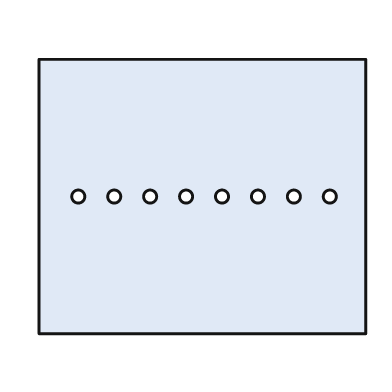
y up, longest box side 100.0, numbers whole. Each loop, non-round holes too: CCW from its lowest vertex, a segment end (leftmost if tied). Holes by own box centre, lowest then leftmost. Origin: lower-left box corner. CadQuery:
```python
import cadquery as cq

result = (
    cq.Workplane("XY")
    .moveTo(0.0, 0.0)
    .lineTo(100.0, 0.0)
    .lineTo(100.0, 84.0)
    .lineTo(0.0, 84.0)
    .close()
    .moveTo(12.0, 42.0)
    .circle(2.0)
    .moveTo(23.0, 42.0)
    .circle(2.0)
    .moveTo(34.0, 42.0)
    .circle(2.0)
    .moveTo(45.0, 42.0)
    .circle(2.0)
    .moveTo(56.0, 42.0)
    .circle(2.0)
    .moveTo(67.0, 42.0)
    .circle(2.0)
    .moveTo(78.0, 42.0)
    .circle(2.0)
    .moveTo(89.0, 42.0)
    .circle(2.0)
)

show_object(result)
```